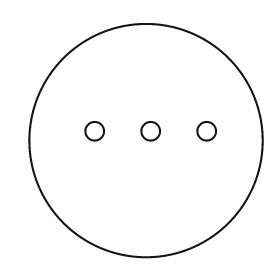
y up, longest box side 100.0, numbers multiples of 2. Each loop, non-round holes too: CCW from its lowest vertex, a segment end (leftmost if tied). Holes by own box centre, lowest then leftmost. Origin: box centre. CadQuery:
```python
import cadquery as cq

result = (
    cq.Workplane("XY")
    .moveTo(0.0, 0.0)
    .circle(50.0)
    .moveTo(-22.0, 4.0)
    .circle(4.0)
    .moveTo(2.0, 4.0)
    .circle(4.0)
    .moveTo(26.0, 4.0)
    .circle(4.0)
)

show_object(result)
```